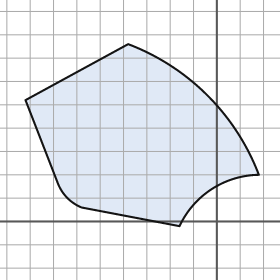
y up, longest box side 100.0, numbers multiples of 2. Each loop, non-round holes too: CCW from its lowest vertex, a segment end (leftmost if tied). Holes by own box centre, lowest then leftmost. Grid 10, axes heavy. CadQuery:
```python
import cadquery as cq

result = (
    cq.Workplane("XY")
    .moveTo(-16.0, -2.0)
    .threePointArc((-2.0, 14.0), (18.0, 20.0))
    .threePointArc((-4.0, 54.0), (-38.0, 76.0))
    .lineTo(-82.0, 52.0)
    .lineTo(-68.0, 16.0)
    .threePointArc((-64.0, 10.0), (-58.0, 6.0))
    .close()
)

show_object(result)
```